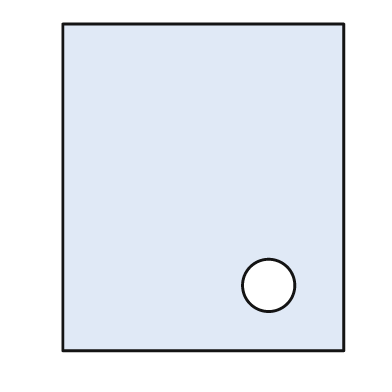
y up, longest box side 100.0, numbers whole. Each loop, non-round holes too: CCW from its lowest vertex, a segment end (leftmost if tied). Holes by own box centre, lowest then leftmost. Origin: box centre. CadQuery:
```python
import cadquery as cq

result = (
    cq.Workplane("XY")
    .moveTo(-43.0, -50.0)
    .lineTo(43.0, -50.0)
    .lineTo(43.0, 50.0)
    .lineTo(-43.0, 50.0)
    .close()
    .moveTo(20.0, -30.0)
    .circle(8.0)
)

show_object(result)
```